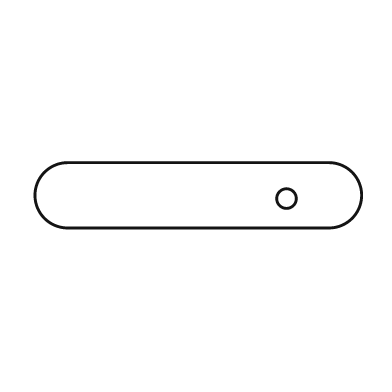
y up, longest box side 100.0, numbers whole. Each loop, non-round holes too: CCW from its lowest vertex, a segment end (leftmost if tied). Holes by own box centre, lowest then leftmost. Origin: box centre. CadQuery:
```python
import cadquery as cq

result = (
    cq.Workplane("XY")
    .moveTo(-40.0, -10.0)
    .lineTo(40.0, -10.0)
    .threePointArc((50.0, 0.0), (40.0, 10.0))
    .lineTo(-40.0, 10.0)
    .threePointArc((-50.0, 0.0), (-40.0, -10.0))
    .close()
    .moveTo(27.0, -1.0)
    .circle(3.0)
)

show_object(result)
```